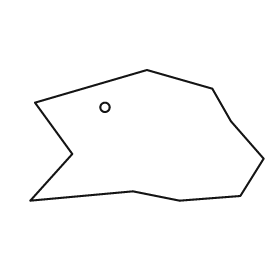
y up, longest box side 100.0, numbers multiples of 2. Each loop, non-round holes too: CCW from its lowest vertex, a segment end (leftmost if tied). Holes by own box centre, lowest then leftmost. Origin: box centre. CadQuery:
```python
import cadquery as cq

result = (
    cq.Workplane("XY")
    .moveTo(-50.0, -28.0)
    .lineTo(-6.0, -24.0)
    .lineTo(14.0, -28.0)
    .lineTo(40.0, -26.0)
    .lineTo(50.0, -10.0)
    .lineTo(36.0, 6.0)
    .lineTo(28.0, 20.0)
    .lineTo(0.0, 28.0)
    .lineTo(-48.0, 14.0)
    .lineTo(-32.0, -8.0)
    .close()
    .moveTo(-18.0, 12.0)
    .circle(2.0)
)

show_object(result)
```